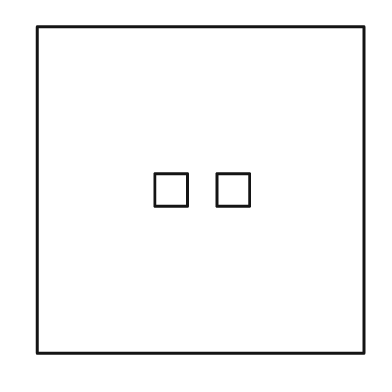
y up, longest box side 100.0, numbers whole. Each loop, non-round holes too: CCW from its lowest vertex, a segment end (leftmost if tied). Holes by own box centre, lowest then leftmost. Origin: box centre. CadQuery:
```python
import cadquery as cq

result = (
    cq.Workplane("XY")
    .moveTo(-50.0, -50.0)
    .lineTo(50.0, -50.0)
    .lineTo(50.0, 50.0)
    .lineTo(-50.0, 50.0)
    .close()
    .moveTo(-14.0, -5.0)
    .lineTo(-4.0, -5.0)
    .lineTo(-4.0, 5.0)
    .lineTo(-14.0, 5.0)
    .close()
    .moveTo(5.0, -5.0)
    .lineTo(15.0, -5.0)
    .lineTo(15.0, 5.0)
    .lineTo(5.0, 5.0)
    .close()
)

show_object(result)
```